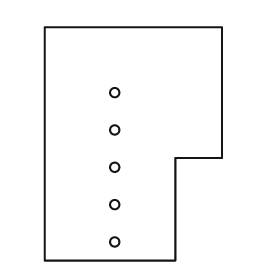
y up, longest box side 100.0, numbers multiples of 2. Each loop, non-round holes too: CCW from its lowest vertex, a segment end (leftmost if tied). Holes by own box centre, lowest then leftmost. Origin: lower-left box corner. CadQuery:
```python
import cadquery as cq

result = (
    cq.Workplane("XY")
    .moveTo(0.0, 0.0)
    .lineTo(56.0, 0.0)
    .lineTo(56.0, 44.0)
    .lineTo(76.0, 44.0)
    .lineTo(76.0, 100.0)
    .lineTo(0.0, 100.0)
    .close()
    .moveTo(30.0, 8.0)
    .circle(2.0)
    .moveTo(30.0, 24.0)
    .circle(2.0)
    .moveTo(30.0, 40.0)
    .circle(2.0)
    .moveTo(30.0, 56.0)
    .circle(2.0)
    .moveTo(30.0, 72.0)
    .circle(2.0)
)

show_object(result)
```